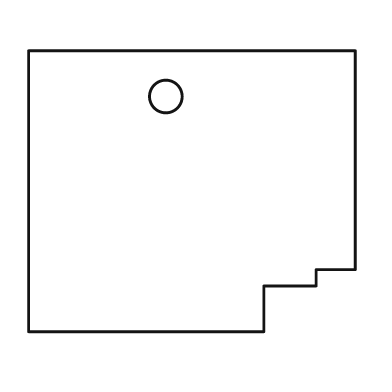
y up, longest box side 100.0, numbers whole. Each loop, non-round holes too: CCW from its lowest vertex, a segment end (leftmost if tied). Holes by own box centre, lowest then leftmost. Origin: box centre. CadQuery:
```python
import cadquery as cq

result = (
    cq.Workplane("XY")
    .moveTo(-50.0, -43.0)
    .lineTo(22.0, -43.0)
    .lineTo(22.0, -29.0)
    .lineTo(38.0, -29.0)
    .lineTo(38.0, -24.0)
    .lineTo(50.0, -24.0)
    .lineTo(50.0, 43.0)
    .lineTo(-50.0, 43.0)
    .close()
    .moveTo(-8.0, 29.0)
    .circle(5.0)
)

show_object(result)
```